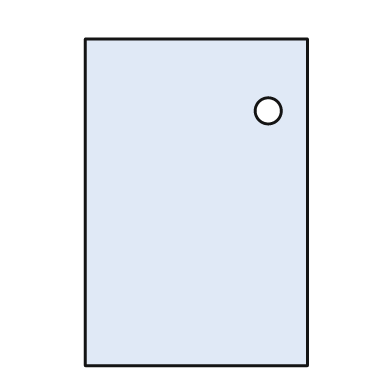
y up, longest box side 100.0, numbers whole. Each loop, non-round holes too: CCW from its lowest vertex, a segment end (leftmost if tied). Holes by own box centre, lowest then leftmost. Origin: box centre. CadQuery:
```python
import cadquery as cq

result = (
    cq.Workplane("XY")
    .moveTo(-34.0, -50.0)
    .lineTo(34.0, -50.0)
    .lineTo(34.0, 50.0)
    .lineTo(-34.0, 50.0)
    .close()
    .moveTo(22.0, 28.0)
    .circle(4.0)
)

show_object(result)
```